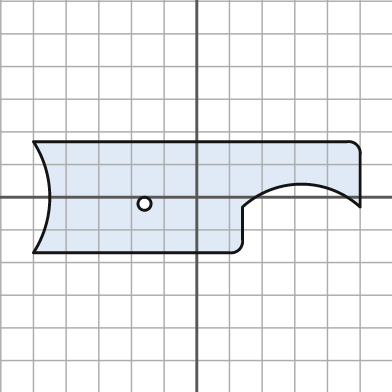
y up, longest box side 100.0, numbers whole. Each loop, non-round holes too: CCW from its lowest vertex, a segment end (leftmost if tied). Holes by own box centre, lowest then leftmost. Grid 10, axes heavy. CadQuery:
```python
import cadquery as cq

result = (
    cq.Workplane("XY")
    .moveTo(-50.0, -17.0)
    .lineTo(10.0, -17.0)
    .threePointArc((13.0, -16.0), (14.0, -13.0))
    .lineTo(14.0, -3.0)
    .threePointArc((32.0, 4.0), (50.0, -3.0))
    .lineTo(50.0, 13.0)
    .threePointArc((49.0, 16.0), (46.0, 17.0))
    .lineTo(-50.0, 17.0)
    .threePointArc((-45.0, 0.0), (-50.0, -17.0))
    .close()
    .moveTo(-16.0, -2.0)
    .circle(2.0)
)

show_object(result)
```